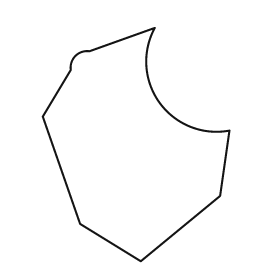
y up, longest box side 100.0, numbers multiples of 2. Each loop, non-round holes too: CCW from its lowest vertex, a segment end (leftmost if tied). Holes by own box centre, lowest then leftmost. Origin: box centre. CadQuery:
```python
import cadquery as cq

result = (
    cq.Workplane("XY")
    .moveTo(2.0, -50.0)
    .lineTo(36.0, -22.0)
    .lineTo(40.0, 6.0)
    .threePointArc((10.0, 18.0), (8.0, 50.0))
    .lineTo(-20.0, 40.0)
    .threePointArc((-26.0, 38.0), (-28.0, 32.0))
    .lineTo(-40.0, 12.0)
    .lineTo(-24.0, -34.0)
    .close()
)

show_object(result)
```